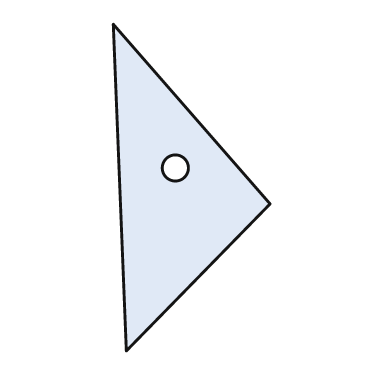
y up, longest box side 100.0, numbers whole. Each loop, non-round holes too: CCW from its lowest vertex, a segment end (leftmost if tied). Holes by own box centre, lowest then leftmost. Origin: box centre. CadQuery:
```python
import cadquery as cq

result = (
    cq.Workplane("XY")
    .moveTo(-20.0, -50.0)
    .lineTo(24.0, -5.0)
    .lineTo(-24.0, 50.0)
    .close()
    .moveTo(-5.0, 6.0)
    .circle(4.0)
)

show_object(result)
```